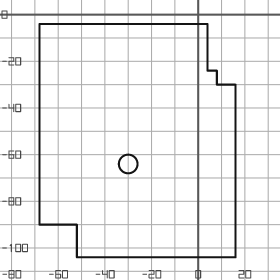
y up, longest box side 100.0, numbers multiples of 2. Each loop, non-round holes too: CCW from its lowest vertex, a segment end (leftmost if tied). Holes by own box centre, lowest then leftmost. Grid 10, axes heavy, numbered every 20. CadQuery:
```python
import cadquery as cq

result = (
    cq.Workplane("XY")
    .moveTo(-52.0, -104.0)
    .lineTo(16.0, -104.0)
    .lineTo(16.0, -30.0)
    .lineTo(8.0, -30.0)
    .lineTo(8.0, -24.0)
    .lineTo(4.0, -24.0)
    .lineTo(4.0, -4.0)
    .lineTo(-68.0, -4.0)
    .lineTo(-68.0, -90.0)
    .lineTo(-52.0, -90.0)
    .close()
    .moveTo(-30.0, -64.0)
    .circle(4.0)
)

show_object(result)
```